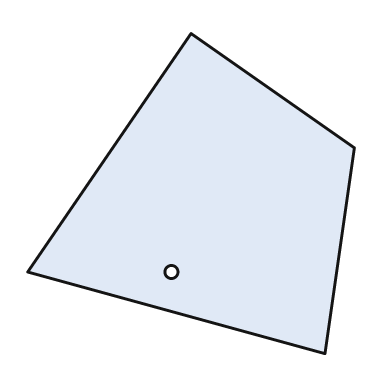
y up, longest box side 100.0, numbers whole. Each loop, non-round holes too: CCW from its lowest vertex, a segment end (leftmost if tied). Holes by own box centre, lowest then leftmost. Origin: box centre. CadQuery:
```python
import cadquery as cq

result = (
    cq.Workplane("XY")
    .moveTo(41.0, -49.0)
    .lineTo(50.0, 14.0)
    .lineTo(0.0, 49.0)
    .lineTo(-50.0, -24.0)
    .close()
    .moveTo(-6.0, -24.0)
    .circle(2.0)
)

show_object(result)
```